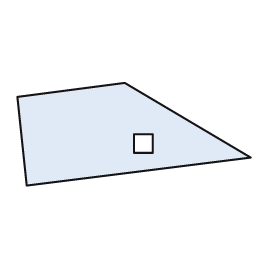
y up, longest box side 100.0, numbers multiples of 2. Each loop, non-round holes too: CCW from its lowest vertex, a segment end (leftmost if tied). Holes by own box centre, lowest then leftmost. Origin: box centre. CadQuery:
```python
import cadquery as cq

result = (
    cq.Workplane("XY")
    .moveTo(-46.0, -22.0)
    .lineTo(50.0, -10.0)
    .lineTo(-4.0, 22.0)
    .lineTo(-50.0, 16.0)
    .close()
    .moveTo(0.0, -8.0)
    .lineTo(8.0, -8.0)
    .lineTo(8.0, 0.0)
    .lineTo(0.0, 0.0)
    .close()
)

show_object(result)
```